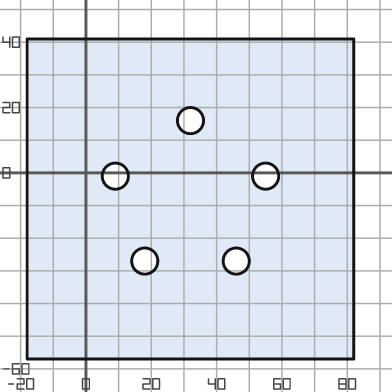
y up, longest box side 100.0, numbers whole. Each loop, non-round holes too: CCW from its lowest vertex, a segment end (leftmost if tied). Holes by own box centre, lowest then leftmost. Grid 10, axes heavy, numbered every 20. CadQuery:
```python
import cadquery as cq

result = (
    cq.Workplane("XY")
    .moveTo(-18.0, -57.0)
    .lineTo(82.0, -57.0)
    .lineTo(82.0, 41.0)
    .lineTo(-18.0, 41.0)
    .close()
    .moveTo(18.0, -27.0)
    .circle(4.0)
    .moveTo(46.0, -27.0)
    .circle(4.0)
    .moveTo(9.0, -1.0)
    .circle(4.0)
    .moveTo(55.0, -1.0)
    .circle(4.0)
    .moveTo(32.0, 16.0)
    .circle(4.0)
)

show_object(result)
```